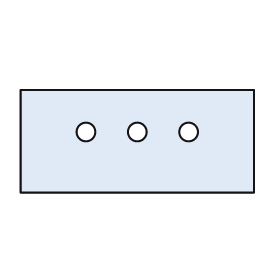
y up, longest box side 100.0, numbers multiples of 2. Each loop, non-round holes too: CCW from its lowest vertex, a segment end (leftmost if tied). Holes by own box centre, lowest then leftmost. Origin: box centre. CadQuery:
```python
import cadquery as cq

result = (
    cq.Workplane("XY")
    .moveTo(-50.0, -22.0)
    .lineTo(50.0, -22.0)
    .lineTo(50.0, 22.0)
    .lineTo(-50.0, 22.0)
    .close()
    .moveTo(-22.0, 4.0)
    .circle(4.0)
    .moveTo(0.0, 4.0)
    .circle(4.0)
    .moveTo(22.0, 4.0)
    .circle(4.0)
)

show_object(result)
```